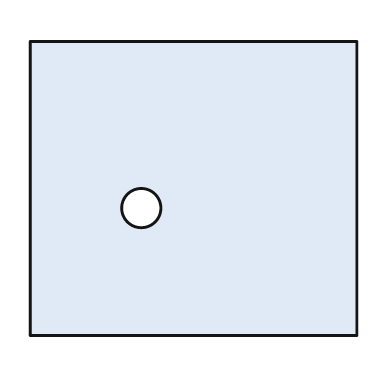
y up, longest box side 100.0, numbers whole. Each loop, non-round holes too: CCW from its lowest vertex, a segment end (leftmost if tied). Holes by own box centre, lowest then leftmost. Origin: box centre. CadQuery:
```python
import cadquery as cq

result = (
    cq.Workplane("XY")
    .moveTo(-50.0, -45.0)
    .lineTo(50.0, -45.0)
    .lineTo(50.0, 45.0)
    .lineTo(-50.0, 45.0)
    .close()
    .moveTo(-16.0, -6.0)
    .circle(6.0)
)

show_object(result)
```